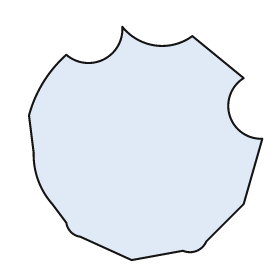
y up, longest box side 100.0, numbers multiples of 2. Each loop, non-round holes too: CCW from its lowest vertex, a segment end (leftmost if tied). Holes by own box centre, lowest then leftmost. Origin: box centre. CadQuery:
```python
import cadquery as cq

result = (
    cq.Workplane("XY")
    .moveTo(-6.0, -50.0)
    .lineTo(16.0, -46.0)
    .threePointArc((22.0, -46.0), (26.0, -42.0))
    .lineTo(42.0, -26.0)
    .lineTo(50.0, 2.0)
    .threePointArc((36.0, 12.0), (42.0, 28.0))
    .lineTo(20.0, 46.0)
    .threePointArc((4.0, 42.0), (-10.0, 50.0))
    .threePointArc((-18.0, 36.0), (-34.0, 38.0))
    .threePointArc((-44.0, 26.0), (-50.0, 12.0))
    .lineTo(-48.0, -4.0)
    .threePointArc((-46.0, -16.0), (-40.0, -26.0))
    .lineTo(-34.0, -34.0)
    .threePointArc((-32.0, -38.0), (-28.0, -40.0))
    .close()
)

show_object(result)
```